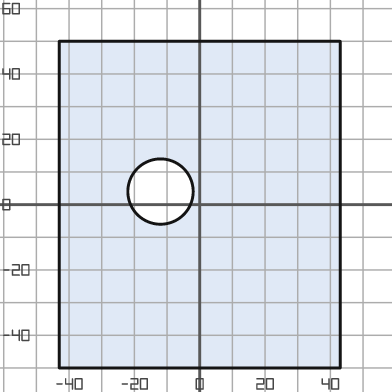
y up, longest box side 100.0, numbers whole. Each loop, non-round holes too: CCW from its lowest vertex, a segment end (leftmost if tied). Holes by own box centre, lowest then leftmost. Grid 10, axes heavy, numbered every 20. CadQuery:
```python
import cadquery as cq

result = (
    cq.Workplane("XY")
    .moveTo(-43.0, -50.0)
    .lineTo(43.0, -50.0)
    .lineTo(43.0, 50.0)
    .lineTo(-43.0, 50.0)
    .close()
    .moveTo(-12.0, 4.0)
    .circle(10.0)
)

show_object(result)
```